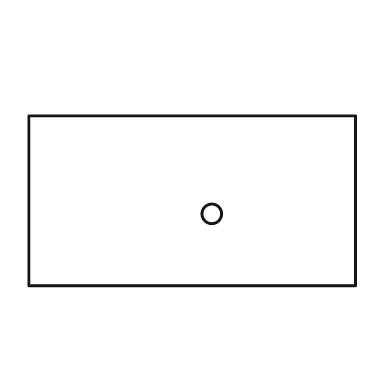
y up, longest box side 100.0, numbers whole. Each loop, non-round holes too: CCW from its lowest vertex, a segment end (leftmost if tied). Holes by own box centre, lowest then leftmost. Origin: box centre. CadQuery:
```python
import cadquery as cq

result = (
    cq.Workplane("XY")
    .moveTo(-50.0, -26.0)
    .lineTo(50.0, -26.0)
    .lineTo(50.0, 26.0)
    .lineTo(-50.0, 26.0)
    .close()
    .moveTo(6.0, -4.0)
    .circle(3.0)
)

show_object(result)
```